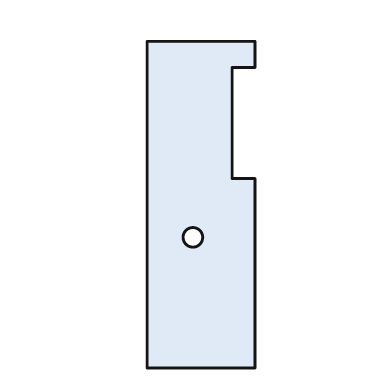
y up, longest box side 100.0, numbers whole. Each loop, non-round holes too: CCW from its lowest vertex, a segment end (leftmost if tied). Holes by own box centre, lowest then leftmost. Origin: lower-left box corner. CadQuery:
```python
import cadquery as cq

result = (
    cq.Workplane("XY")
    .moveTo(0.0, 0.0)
    .lineTo(33.0, 0.0)
    .lineTo(33.0, 58.0)
    .lineTo(26.0, 58.0)
    .lineTo(26.0, 92.0)
    .lineTo(33.0, 92.0)
    .lineTo(33.0, 100.0)
    .lineTo(0.0, 100.0)
    .close()
    .moveTo(14.0, 40.0)
    .circle(3.0)
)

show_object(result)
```